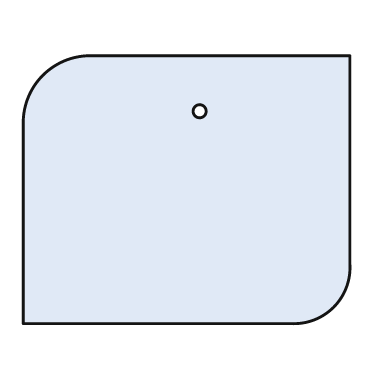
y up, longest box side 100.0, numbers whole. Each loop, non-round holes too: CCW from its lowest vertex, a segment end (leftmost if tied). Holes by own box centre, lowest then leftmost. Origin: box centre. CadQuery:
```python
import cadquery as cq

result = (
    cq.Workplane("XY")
    .moveTo(-50.0, -41.0)
    .lineTo(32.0, -41.0)
    .threePointArc((45.0, -36.0), (50.0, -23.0))
    .lineTo(50.0, 41.0)
    .lineTo(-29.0, 41.0)
    .threePointArc((-44.0, 35.0), (-50.0, 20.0))
    .close()
    .moveTo(4.0, 24.0)
    .circle(2.0)
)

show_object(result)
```